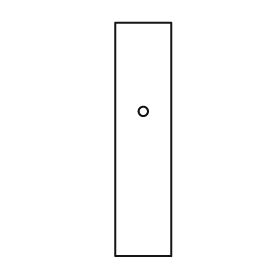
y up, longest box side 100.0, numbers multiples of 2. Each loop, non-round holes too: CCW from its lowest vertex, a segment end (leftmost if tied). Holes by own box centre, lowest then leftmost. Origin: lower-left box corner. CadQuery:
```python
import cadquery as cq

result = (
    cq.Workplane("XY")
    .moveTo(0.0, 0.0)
    .lineTo(24.0, 0.0)
    .lineTo(24.0, 100.0)
    .lineTo(0.0, 100.0)
    .close()
    .moveTo(12.0, 62.0)
    .circle(2.0)
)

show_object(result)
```